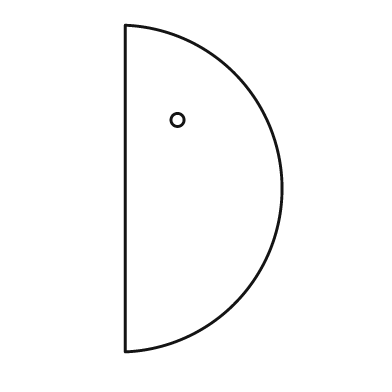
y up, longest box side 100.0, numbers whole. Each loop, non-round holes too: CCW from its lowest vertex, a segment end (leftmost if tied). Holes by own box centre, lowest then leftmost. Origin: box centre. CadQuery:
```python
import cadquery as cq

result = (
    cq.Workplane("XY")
    .moveTo(-24.0, -50.0)
    .threePointArc((24.0, 0.0), (-24.0, 50.0))
    .close()
    .moveTo(-8.0, 21.0)
    .circle(2.0)
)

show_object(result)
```